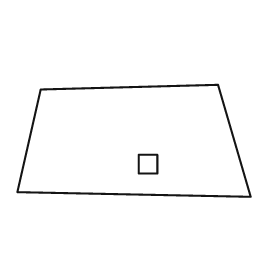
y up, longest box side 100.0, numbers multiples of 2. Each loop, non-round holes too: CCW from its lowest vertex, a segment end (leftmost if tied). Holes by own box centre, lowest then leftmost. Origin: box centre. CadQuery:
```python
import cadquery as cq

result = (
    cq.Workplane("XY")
    .moveTo(50.0, -24.0)
    .lineTo(36.0, 24.0)
    .lineTo(-40.0, 22.0)
    .lineTo(-50.0, -22.0)
    .close()
    .moveTo(2.0, -14.0)
    .lineTo(10.0, -14.0)
    .lineTo(10.0, -6.0)
    .lineTo(2.0, -6.0)
    .close()
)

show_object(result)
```